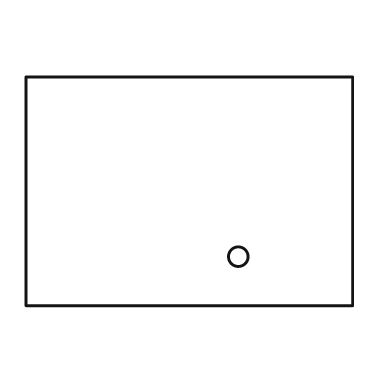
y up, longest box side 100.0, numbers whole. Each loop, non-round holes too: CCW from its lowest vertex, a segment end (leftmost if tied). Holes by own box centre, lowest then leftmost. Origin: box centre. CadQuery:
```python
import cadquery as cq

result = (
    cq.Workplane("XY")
    .moveTo(-50.0, -35.0)
    .lineTo(50.0, -35.0)
    .lineTo(50.0, 35.0)
    .lineTo(-50.0, 35.0)
    .close()
    .moveTo(15.0, -20.0)
    .circle(3.0)
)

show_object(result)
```